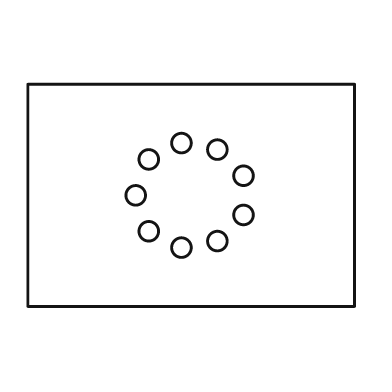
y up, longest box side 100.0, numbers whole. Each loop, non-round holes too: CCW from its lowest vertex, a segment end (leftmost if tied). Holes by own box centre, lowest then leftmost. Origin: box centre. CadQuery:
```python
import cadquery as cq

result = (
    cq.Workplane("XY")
    .moveTo(-50.0, -34.0)
    .lineTo(50.0, -34.0)
    .lineTo(50.0, 34.0)
    .lineTo(-50.0, 34.0)
    .close()
    .moveTo(-3.0, -16.0)
    .circle(3.0)
    .moveTo(8.0, -14.0)
    .circle(3.0)
    .moveTo(-13.0, -11.0)
    .circle(3.0)
    .moveTo(16.0, -6.0)
    .circle(3.0)
    .moveTo(-17.0, 0.0)
    .circle(3.0)
    .moveTo(16.0, 6.0)
    .circle(3.0)
    .moveTo(-13.0, 11.0)
    .circle(3.0)
    .moveTo(8.0, 14.0)
    .circle(3.0)
    .moveTo(-3.0, 16.0)
    .circle(3.0)
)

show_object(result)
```